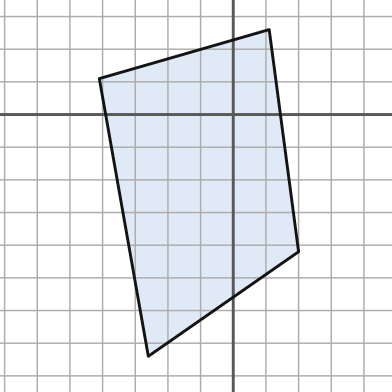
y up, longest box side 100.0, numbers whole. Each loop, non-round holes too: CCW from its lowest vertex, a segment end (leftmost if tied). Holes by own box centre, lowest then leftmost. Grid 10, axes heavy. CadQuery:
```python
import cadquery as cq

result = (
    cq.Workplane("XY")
    .moveTo(-26.0, -74.0)
    .lineTo(20.0, -42.0)
    .lineTo(11.0, 26.0)
    .lineTo(-41.0, 11.0)
    .close()
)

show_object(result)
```